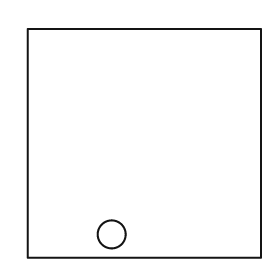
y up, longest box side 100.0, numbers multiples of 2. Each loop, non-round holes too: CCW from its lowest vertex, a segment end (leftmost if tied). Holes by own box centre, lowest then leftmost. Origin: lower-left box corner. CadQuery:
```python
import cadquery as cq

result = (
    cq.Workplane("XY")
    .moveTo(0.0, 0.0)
    .lineTo(100.0, 0.0)
    .lineTo(100.0, 98.0)
    .lineTo(0.0, 98.0)
    .close()
    .moveTo(36.0, 10.0)
    .circle(6.0)
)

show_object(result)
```